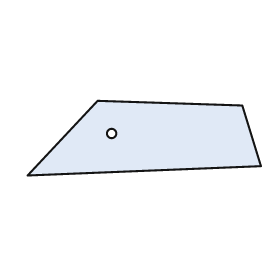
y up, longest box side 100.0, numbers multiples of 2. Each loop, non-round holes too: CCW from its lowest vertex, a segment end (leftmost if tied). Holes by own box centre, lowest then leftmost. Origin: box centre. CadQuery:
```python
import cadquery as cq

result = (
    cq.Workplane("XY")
    .moveTo(-50.0, -16.0)
    .lineTo(50.0, -12.0)
    .lineTo(42.0, 14.0)
    .lineTo(-20.0, 16.0)
    .close()
    .moveTo(-14.0, 2.0)
    .circle(2.0)
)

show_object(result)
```